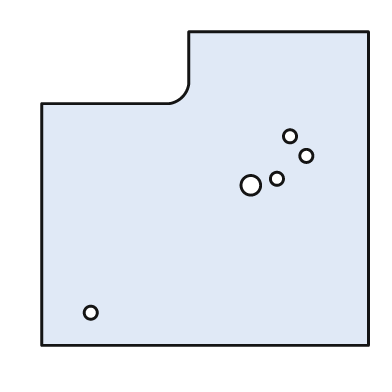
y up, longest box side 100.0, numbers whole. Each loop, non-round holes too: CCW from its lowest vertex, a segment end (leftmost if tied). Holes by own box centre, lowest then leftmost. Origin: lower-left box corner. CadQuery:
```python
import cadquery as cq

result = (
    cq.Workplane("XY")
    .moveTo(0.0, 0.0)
    .lineTo(100.0, 0.0)
    .lineTo(100.0, 96.0)
    .lineTo(45.0, 96.0)
    .lineTo(45.0, 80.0)
    .threePointArc((43.0, 76.0), (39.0, 74.0))
    .lineTo(0.0, 74.0)
    .close()
    .moveTo(15.0, 10.0)
    .circle(2.0)
    .moveTo(64.0, 49.0)
    .circle(3.0)
    .moveTo(72.0, 51.0)
    .circle(2.0)
    .moveTo(81.0, 58.0)
    .circle(2.0)
    .moveTo(76.0, 64.0)
    .circle(2.0)
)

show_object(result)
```